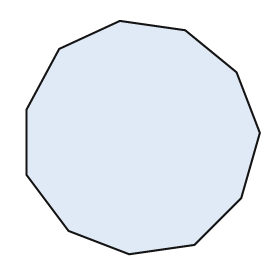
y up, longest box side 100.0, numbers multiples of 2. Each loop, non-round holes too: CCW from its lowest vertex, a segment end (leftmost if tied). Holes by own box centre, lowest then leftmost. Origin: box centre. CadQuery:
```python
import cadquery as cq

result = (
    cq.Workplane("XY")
    .moveTo(-6.0, -50.0)
    .lineTo(22.0, -46.0)
    .lineTo(42.0, -26.0)
    .lineTo(50.0, 2.0)
    .lineTo(40.0, 28.0)
    .lineTo(18.0, 46.0)
    .lineTo(-10.0, 50.0)
    .lineTo(-36.0, 38.0)
    .lineTo(-50.0, 12.0)
    .lineTo(-50.0, -16.0)
    .lineTo(-32.0, -40.0)
    .close()
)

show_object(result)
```